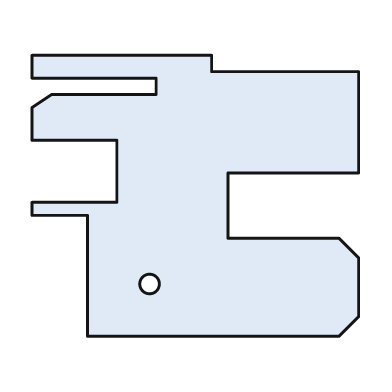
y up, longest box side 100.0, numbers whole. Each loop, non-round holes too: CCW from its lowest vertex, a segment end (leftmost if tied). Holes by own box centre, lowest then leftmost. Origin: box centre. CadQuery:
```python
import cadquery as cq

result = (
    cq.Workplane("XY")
    .moveTo(-33.0, -43.0)
    .lineTo(44.0, -43.0)
    .lineTo(50.0, -37.0)
    .lineTo(50.0, -19.0)
    .lineTo(44.0, -13.0)
    .lineTo(10.0, -13.0)
    .lineTo(10.0, 7.0)
    .lineTo(50.0, 7.0)
    .lineTo(50.0, 38.0)
    .lineTo(5.0, 38.0)
    .lineTo(5.0, 43.0)
    .lineTo(-50.0, 43.0)
    .lineTo(-50.0, 36.0)
    .lineTo(-12.0, 36.0)
    .lineTo(-12.0, 31.0)
    .lineTo(-44.0, 31.0)
    .lineTo(-50.0, 27.0)
    .lineTo(-50.0, 17.0)
    .lineTo(-24.0, 17.0)
    .lineTo(-24.0, -2.0)
    .lineTo(-50.0, -2.0)
    .lineTo(-50.0, -6.0)
    .lineTo(-33.0, -6.0)
    .close()
    .moveTo(-14.0, -27.0)
    .circle(3.0)
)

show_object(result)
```